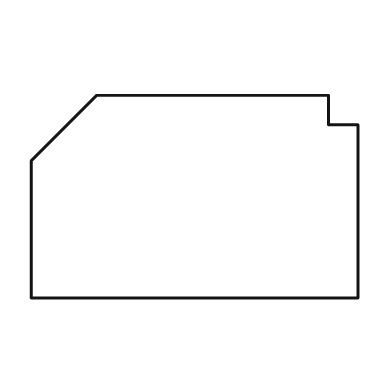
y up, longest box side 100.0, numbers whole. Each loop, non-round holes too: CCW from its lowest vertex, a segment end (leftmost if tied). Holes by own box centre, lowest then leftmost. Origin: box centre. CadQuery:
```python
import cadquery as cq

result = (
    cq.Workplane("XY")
    .moveTo(-50.0, -31.0)
    .lineTo(50.0, -31.0)
    .lineTo(50.0, 22.0)
    .lineTo(41.0, 22.0)
    .lineTo(41.0, 31.0)
    .lineTo(-30.0, 31.0)
    .lineTo(-50.0, 11.0)
    .close()
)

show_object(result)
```